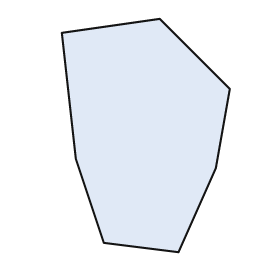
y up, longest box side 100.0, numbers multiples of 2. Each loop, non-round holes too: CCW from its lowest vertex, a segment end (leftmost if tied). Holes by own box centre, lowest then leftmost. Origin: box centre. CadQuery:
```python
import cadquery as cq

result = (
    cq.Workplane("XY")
    .moveTo(14.0, -50.0)
    .lineTo(30.0, -14.0)
    .lineTo(36.0, 20.0)
    .lineTo(6.0, 50.0)
    .lineTo(-36.0, 44.0)
    .lineTo(-30.0, -10.0)
    .lineTo(-18.0, -46.0)
    .close()
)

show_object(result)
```